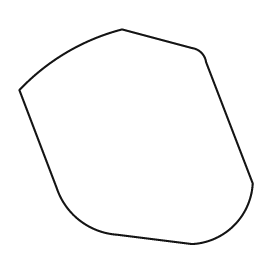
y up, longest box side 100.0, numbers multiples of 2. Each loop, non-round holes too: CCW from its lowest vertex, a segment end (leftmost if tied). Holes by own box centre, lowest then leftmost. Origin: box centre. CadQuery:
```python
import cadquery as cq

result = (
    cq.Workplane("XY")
    .moveTo(24.0, -46.0)
    .threePointArc((42.0, -38.0), (50.0, -20.0))
    .lineTo(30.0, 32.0)
    .threePointArc((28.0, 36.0), (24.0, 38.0))
    .lineTo(-6.0, 46.0)
    .threePointArc((-30.0, 36.0), (-50.0, 20.0))
    .lineTo(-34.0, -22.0)
    .threePointArc((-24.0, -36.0), (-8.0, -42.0))
    .close()
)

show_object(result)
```